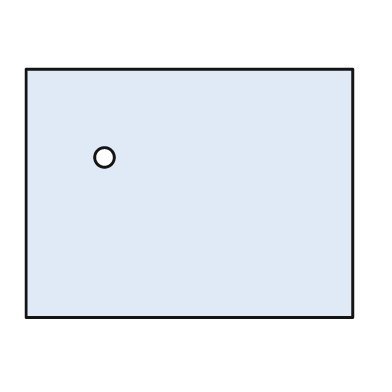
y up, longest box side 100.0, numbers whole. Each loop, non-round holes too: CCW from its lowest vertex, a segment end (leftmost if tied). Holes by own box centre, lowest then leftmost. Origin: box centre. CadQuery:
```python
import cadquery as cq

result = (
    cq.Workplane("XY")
    .moveTo(-50.0, -38.0)
    .lineTo(50.0, -38.0)
    .lineTo(50.0, 38.0)
    .lineTo(-50.0, 38.0)
    .close()
    .moveTo(-26.0, 11.0)
    .circle(3.0)
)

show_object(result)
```